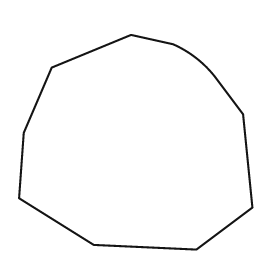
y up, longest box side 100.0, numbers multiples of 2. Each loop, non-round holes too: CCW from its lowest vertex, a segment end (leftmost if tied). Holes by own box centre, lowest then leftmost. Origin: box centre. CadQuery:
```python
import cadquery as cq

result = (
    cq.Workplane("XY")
    .moveTo(26.0, -46.0)
    .lineTo(50.0, -28.0)
    .lineTo(46.0, 12.0)
    .lineTo(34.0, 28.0)
    .threePointArc((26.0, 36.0), (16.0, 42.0))
    .lineTo(-2.0, 46.0)
    .lineTo(-36.0, 32.0)
    .lineTo(-48.0, 4.0)
    .lineTo(-50.0, -24.0)
    .lineTo(-18.0, -44.0)
    .close()
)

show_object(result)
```